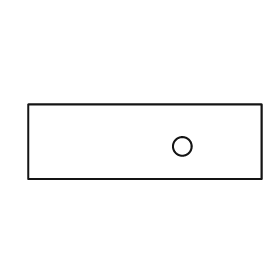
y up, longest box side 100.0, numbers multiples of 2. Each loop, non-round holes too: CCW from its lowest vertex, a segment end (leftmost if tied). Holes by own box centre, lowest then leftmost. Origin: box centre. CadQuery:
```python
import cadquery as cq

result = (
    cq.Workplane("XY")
    .moveTo(-50.0, -16.0)
    .lineTo(50.0, -16.0)
    .lineTo(50.0, 16.0)
    .lineTo(-50.0, 16.0)
    .close()
    .moveTo(16.0, -2.0)
    .circle(4.0)
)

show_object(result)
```